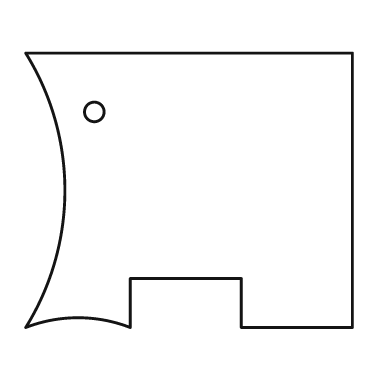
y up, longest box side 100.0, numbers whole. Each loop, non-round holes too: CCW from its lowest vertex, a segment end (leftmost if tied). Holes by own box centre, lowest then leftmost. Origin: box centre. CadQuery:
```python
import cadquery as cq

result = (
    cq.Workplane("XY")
    .moveTo(-50.0, -42.0)
    .threePointArc((-34.0, -39.0), (-18.0, -42.0))
    .lineTo(-18.0, -27.0)
    .lineTo(16.0, -27.0)
    .lineTo(16.0, -42.0)
    .lineTo(50.0, -42.0)
    .lineTo(50.0, 42.0)
    .lineTo(-50.0, 42.0)
    .threePointArc((-38.0, 0.0), (-50.0, -42.0))
    .close()
    .moveTo(-29.0, 24.0)
    .circle(3.0)
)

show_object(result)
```